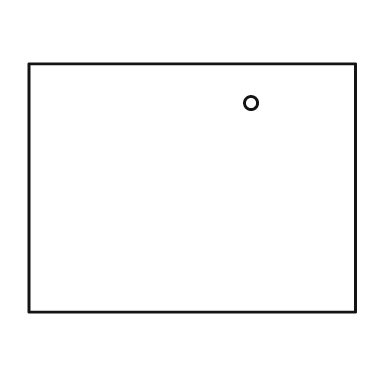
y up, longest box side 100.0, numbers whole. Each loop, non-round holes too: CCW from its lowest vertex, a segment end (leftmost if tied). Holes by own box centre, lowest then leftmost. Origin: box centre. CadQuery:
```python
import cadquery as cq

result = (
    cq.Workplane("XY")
    .moveTo(-50.0, -38.0)
    .lineTo(50.0, -38.0)
    .lineTo(50.0, 38.0)
    .lineTo(-50.0, 38.0)
    .close()
    .moveTo(18.0, 26.0)
    .circle(2.0)
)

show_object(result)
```